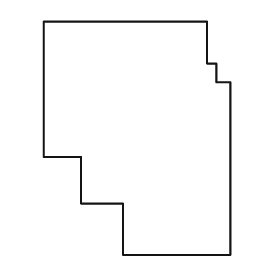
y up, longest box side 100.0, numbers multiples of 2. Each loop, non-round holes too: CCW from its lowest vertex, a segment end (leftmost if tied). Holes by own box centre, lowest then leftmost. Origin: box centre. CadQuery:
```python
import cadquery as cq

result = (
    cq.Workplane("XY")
    .moveTo(-6.0, -50.0)
    .lineTo(40.0, -50.0)
    .lineTo(40.0, 24.0)
    .lineTo(34.0, 24.0)
    .lineTo(34.0, 32.0)
    .lineTo(30.0, 32.0)
    .lineTo(30.0, 50.0)
    .lineTo(-40.0, 50.0)
    .lineTo(-40.0, -8.0)
    .lineTo(-24.0, -8.0)
    .lineTo(-24.0, -28.0)
    .lineTo(-6.0, -28.0)
    .close()
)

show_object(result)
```